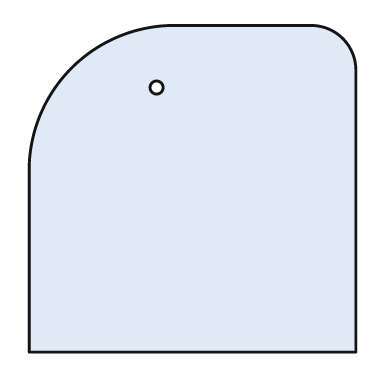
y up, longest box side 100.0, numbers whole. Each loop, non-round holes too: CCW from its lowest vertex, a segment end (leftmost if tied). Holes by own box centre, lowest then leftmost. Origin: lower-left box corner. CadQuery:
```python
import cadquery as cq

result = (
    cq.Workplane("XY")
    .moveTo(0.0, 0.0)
    .lineTo(100.0, 0.0)
    .lineTo(100.0, 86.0)
    .threePointArc((96.0, 96.0), (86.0, 100.0))
    .lineTo(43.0, 100.0)
    .threePointArc((13.0, 87.0), (0.0, 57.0))
    .close()
    .moveTo(39.0, 81.0)
    .circle(2.0)
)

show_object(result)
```